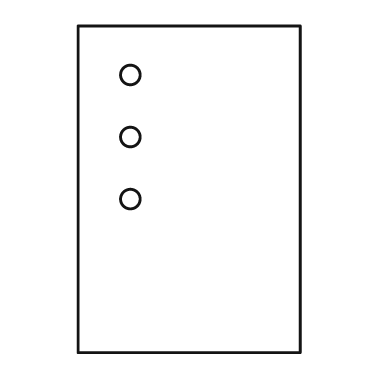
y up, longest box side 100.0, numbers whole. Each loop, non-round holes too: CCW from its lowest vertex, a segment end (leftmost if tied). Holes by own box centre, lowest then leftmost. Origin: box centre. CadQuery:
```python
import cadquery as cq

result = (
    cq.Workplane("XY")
    .moveTo(-34.0, -50.0)
    .lineTo(34.0, -50.0)
    .lineTo(34.0, 50.0)
    .lineTo(-34.0, 50.0)
    .close()
    .moveTo(-18.0, -3.0)
    .circle(3.0)
    .moveTo(-18.0, 16.0)
    .circle(3.0)
    .moveTo(-18.0, 35.0)
    .circle(3.0)
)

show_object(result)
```